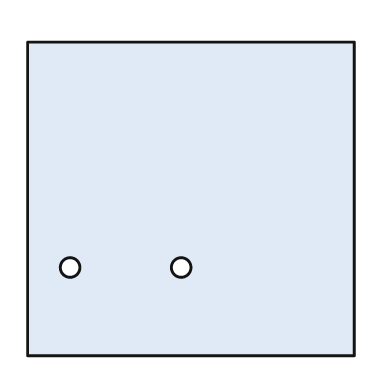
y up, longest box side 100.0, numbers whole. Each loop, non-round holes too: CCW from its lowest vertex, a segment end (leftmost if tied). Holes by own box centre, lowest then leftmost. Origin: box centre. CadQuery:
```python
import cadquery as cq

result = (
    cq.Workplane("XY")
    .moveTo(-50.0, -48.0)
    .lineTo(50.0, -48.0)
    .lineTo(50.0, 48.0)
    .lineTo(-50.0, 48.0)
    .close()
    .moveTo(-37.0, -21.0)
    .circle(3.0)
    .moveTo(-3.0, -21.0)
    .circle(3.0)
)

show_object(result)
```